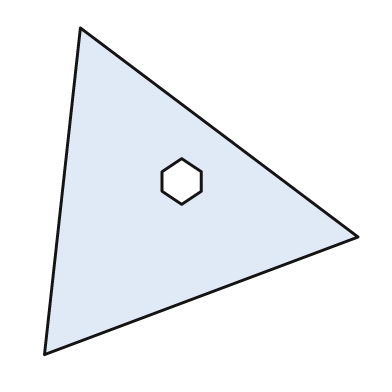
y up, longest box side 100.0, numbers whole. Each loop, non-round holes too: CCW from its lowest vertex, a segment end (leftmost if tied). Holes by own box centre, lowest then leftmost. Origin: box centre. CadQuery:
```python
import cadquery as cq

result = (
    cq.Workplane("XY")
    .moveTo(-48.0, -50.0)
    .lineTo(48.0, -14.0)
    .lineTo(-37.0, 50.0)
    .close()
    .moveTo(-6.0, -4.0)
    .lineTo(0.0, 0.0)
    .lineTo(0.0, 6.0)
    .lineTo(-6.0, 10.0)
    .lineTo(-12.0, 6.0)
    .lineTo(-12.0, 0.0)
    .close()
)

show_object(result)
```